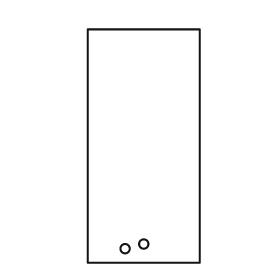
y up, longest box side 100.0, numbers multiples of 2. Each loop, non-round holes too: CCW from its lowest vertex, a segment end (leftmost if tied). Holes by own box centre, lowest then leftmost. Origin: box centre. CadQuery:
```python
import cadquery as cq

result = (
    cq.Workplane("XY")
    .moveTo(-24.0, -50.0)
    .lineTo(24.0, -50.0)
    .lineTo(24.0, 50.0)
    .lineTo(-24.0, 50.0)
    .close()
    .moveTo(-8.0, -44.0)
    .circle(2.0)
    .moveTo(0.0, -42.0)
    .circle(2.0)
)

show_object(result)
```